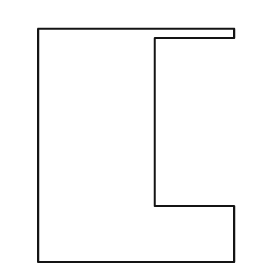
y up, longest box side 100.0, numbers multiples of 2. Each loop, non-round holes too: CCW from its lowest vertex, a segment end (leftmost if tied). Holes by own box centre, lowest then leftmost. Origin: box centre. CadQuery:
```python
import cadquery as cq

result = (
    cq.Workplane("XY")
    .moveTo(-42.0, -50.0)
    .lineTo(42.0, -50.0)
    .lineTo(42.0, -26.0)
    .lineTo(8.0, -26.0)
    .lineTo(8.0, 46.0)
    .lineTo(42.0, 46.0)
    .lineTo(42.0, 50.0)
    .lineTo(-42.0, 50.0)
    .close()
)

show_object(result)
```